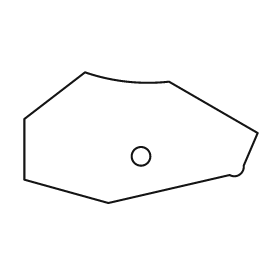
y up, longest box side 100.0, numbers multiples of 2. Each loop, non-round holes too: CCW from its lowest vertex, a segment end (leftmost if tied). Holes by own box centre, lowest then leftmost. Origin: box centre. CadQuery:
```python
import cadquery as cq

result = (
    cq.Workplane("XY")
    .moveTo(-14.0, -28.0)
    .lineTo(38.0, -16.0)
    .threePointArc((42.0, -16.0), (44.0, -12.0))
    .lineTo(50.0, 2.0)
    .lineTo(12.0, 24.0)
    .threePointArc((-6.0, 24.0), (-24.0, 28.0))
    .lineTo(-50.0, 8.0)
    .lineTo(-50.0, -18.0)
    .close()
    .moveTo(0.0, -8.0)
    .circle(4.0)
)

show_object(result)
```